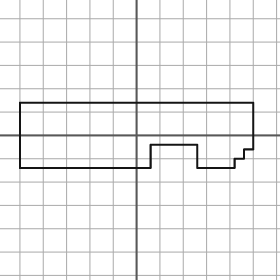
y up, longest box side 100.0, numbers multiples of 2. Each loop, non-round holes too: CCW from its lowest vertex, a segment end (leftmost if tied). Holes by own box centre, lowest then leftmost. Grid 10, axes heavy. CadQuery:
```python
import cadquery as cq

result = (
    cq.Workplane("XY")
    .moveTo(-50.0, -14.0)
    .lineTo(6.0, -14.0)
    .lineTo(6.0, -4.0)
    .lineTo(26.0, -4.0)
    .lineTo(26.0, -14.0)
    .lineTo(42.0, -14.0)
    .lineTo(42.0, -10.0)
    .lineTo(46.0, -10.0)
    .lineTo(46.0, -6.0)
    .lineTo(50.0, -6.0)
    .lineTo(50.0, 14.0)
    .lineTo(-50.0, 14.0)
    .close()
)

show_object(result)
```